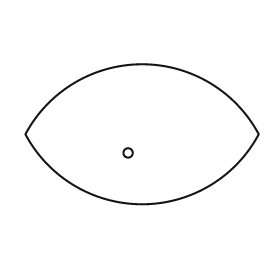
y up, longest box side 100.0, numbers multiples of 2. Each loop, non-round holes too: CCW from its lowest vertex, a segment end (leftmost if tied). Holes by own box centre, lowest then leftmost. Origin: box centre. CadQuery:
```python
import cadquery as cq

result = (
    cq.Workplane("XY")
    .moveTo(-50.0, 0.0)
    .threePointArc((0.0, -30.0), (50.0, 0.0))
    .threePointArc((0.0, 30.0), (-50.0, 0.0))
    .close()
    .moveTo(-6.0, -8.0)
    .circle(2.0)
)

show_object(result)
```